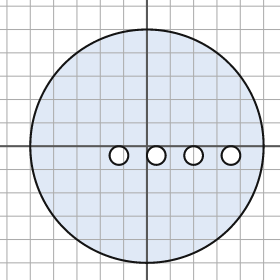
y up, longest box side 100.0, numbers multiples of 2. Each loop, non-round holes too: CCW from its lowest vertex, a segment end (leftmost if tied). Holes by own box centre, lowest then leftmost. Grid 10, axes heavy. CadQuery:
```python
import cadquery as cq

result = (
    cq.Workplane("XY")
    .moveTo(0.0, 0.0)
    .circle(50.0)
    .moveTo(-12.0, -4.0)
    .circle(4.0)
    .moveTo(4.0, -4.0)
    .circle(4.0)
    .moveTo(20.0, -4.0)
    .circle(4.0)
    .moveTo(36.0, -4.0)
    .circle(4.0)
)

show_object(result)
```